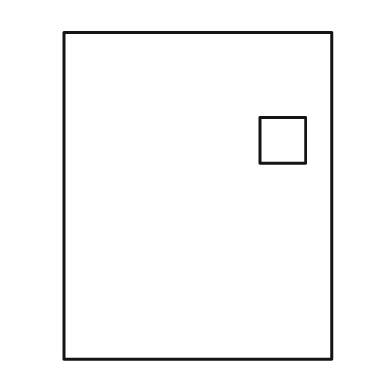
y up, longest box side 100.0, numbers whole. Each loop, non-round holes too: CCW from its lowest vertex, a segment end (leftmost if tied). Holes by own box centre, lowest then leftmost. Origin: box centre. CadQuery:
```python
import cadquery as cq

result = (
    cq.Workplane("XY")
    .moveTo(-41.0, -50.0)
    .lineTo(41.0, -50.0)
    .lineTo(41.0, 50.0)
    .lineTo(-41.0, 50.0)
    .close()
    .moveTo(19.0, 10.0)
    .lineTo(33.0, 10.0)
    .lineTo(33.0, 24.0)
    .lineTo(19.0, 24.0)
    .close()
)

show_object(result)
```